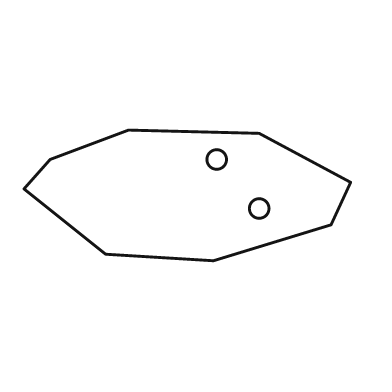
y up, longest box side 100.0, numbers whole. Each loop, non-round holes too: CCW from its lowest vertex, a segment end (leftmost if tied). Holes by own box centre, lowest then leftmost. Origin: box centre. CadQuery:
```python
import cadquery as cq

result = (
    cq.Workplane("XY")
    .moveTo(8.0, -20.0)
    .lineTo(44.0, -9.0)
    .lineTo(50.0, 4.0)
    .lineTo(22.0, 19.0)
    .lineTo(-18.0, 20.0)
    .lineTo(-42.0, 11.0)
    .lineTo(-50.0, 2.0)
    .lineTo(-25.0, -18.0)
    .close()
    .moveTo(22.0, -4.0)
    .circle(3.0)
    .moveTo(9.0, 11.0)
    .circle(3.0)
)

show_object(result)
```